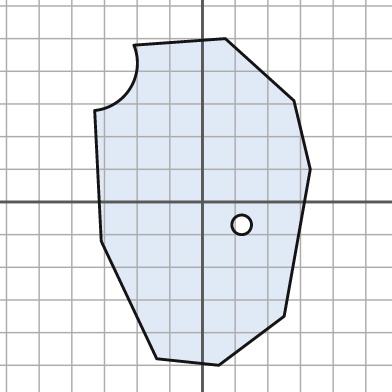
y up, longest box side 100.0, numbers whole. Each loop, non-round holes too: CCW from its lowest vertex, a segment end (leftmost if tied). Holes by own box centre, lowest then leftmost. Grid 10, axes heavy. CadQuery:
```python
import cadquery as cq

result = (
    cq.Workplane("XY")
    .moveTo(5.0, -50.0)
    .lineTo(25.0, -35.0)
    .lineTo(33.0, 10.0)
    .lineTo(28.0, 31.0)
    .lineTo(7.0, 50.0)
    .lineTo(-21.0, 48.0)
    .threePointArc((-22.0, 35.0), (-33.0, 28.0))
    .lineTo(-31.0, -12.0)
    .lineTo(-14.0, -48.0)
    .close()
    .moveTo(12.0, -7.0)
    .circle(3.0)
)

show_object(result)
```